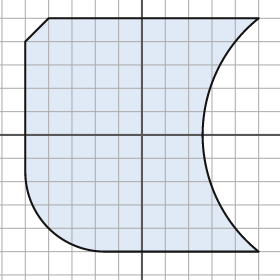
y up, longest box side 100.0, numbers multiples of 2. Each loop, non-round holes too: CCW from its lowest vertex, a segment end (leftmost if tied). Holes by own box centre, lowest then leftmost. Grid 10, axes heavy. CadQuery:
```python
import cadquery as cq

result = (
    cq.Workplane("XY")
    .moveTo(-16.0, -50.0)
    .lineTo(50.0, -50.0)
    .threePointArc((26.0, 0.0), (50.0, 50.0))
    .lineTo(-40.0, 50.0)
    .lineTo(-50.0, 40.0)
    .lineTo(-50.0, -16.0)
    .threePointArc((-40.0, -40.0), (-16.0, -50.0))
    .close()
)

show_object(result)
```